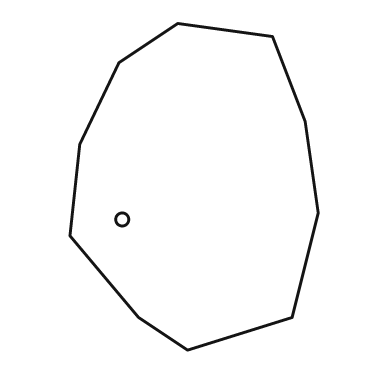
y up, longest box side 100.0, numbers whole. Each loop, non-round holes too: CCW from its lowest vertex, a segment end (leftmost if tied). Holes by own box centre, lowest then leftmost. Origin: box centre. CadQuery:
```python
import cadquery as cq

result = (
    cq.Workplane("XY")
    .moveTo(-2.0, -50.0)
    .lineTo(30.0, -40.0)
    .lineTo(38.0, -8.0)
    .lineTo(34.0, 20.0)
    .lineTo(24.0, 46.0)
    .lineTo(-5.0, 50.0)
    .lineTo(-23.0, 38.0)
    .lineTo(-35.0, 13.0)
    .lineTo(-38.0, -15.0)
    .lineTo(-17.0, -40.0)
    .close()
    .moveTo(-22.0, -10.0)
    .circle(2.0)
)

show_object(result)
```